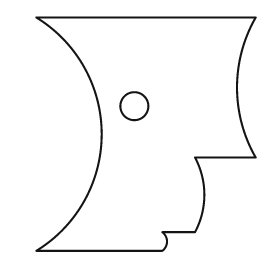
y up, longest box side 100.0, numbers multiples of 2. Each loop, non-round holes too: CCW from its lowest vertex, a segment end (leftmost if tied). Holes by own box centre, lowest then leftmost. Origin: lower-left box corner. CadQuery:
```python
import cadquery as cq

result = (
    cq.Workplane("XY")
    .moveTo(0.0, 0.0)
    .lineTo(54.0, 0.0)
    .threePointArc((56.0, 4.0), (54.0, 8.0))
    .lineTo(68.0, 8.0)
    .threePointArc((72.0, 24.0), (68.0, 40.0))
    .lineTo(94.0, 40.0)
    .threePointArc((86.0, 70.0), (94.0, 100.0))
    .lineTo(0.0, 100.0)
    .threePointArc((28.0, 50.0), (0.0, 0.0))
    .close()
    .moveTo(42.0, 62.0)
    .circle(6.0)
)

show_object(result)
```